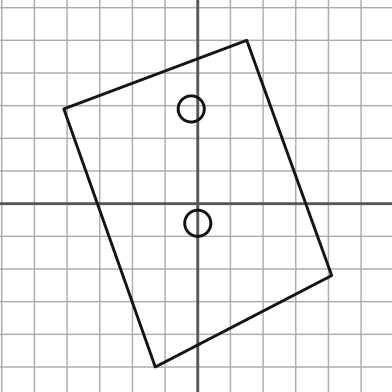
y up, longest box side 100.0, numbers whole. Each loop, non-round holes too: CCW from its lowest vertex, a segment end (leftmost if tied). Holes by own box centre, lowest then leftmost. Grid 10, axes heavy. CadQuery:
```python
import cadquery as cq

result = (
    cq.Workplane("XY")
    .moveTo(-13.0, -50.0)
    .lineTo(41.0, -22.0)
    .lineTo(15.0, 50.0)
    .lineTo(-41.0, 29.0)
    .close()
    .moveTo(0.0, -6.0)
    .circle(4.0)
    .moveTo(-2.0, 29.0)
    .circle(4.0)
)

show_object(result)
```